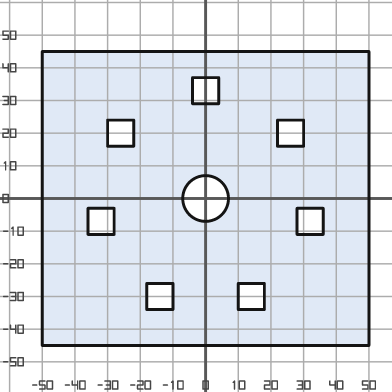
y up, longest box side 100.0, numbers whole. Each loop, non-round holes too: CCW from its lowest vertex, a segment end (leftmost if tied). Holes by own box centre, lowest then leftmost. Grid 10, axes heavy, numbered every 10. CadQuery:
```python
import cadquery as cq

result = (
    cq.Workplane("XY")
    .moveTo(-50.0, -45.0)
    .lineTo(50.0, -45.0)
    .lineTo(50.0, 45.0)
    .lineTo(-50.0, 45.0)
    .close()
    .moveTo(-18.0, -34.0)
    .lineTo(-10.0, -34.0)
    .lineTo(-10.0, -26.0)
    .lineTo(-18.0, -26.0)
    .close()
    .moveTo(10.0, -34.0)
    .lineTo(18.0, -34.0)
    .lineTo(18.0, -26.0)
    .lineTo(10.0, -26.0)
    .close()
    .moveTo(-36.0, -11.0)
    .lineTo(-28.0, -11.0)
    .lineTo(-28.0, -3.0)
    .lineTo(-36.0, -3.0)
    .close()
    .moveTo(28.0, -11.0)
    .lineTo(36.0, -11.0)
    .lineTo(36.0, -3.0)
    .lineTo(28.0, -3.0)
    .close()
    .moveTo(0.0, 0.0)
    .circle(7.0)
    .moveTo(-30.0, 16.0)
    .lineTo(-22.0, 16.0)
    .lineTo(-22.0, 24.0)
    .lineTo(-30.0, 24.0)
    .close()
    .moveTo(22.0, 16.0)
    .lineTo(30.0, 16.0)
    .lineTo(30.0, 24.0)
    .lineTo(22.0, 24.0)
    .close()
    .moveTo(-4.0, 29.0)
    .lineTo(4.0, 29.0)
    .lineTo(4.0, 37.0)
    .lineTo(-4.0, 37.0)
    .close()
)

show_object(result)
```